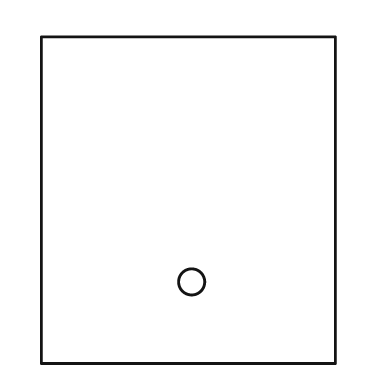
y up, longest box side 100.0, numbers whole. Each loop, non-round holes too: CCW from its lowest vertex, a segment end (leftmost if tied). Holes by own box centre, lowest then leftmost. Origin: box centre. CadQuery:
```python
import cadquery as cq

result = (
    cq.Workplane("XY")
    .moveTo(-45.0, -50.0)
    .lineTo(45.0, -50.0)
    .lineTo(45.0, 50.0)
    .lineTo(-45.0, 50.0)
    .close()
    .moveTo(1.0, -25.0)
    .circle(4.0)
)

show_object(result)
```